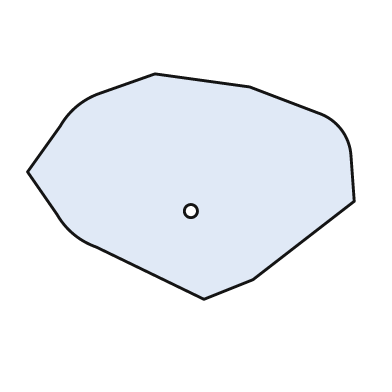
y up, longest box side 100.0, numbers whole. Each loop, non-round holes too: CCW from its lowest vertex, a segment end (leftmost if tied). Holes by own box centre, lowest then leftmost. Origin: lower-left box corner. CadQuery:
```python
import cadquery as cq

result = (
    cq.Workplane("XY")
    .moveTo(54.0, 0.0)
    .lineTo(69.0, 6.0)
    .lineTo(100.0, 30.0)
    .lineTo(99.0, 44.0)
    .threePointArc((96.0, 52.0), (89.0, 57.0))
    .lineTo(68.0, 65.0)
    .lineTo(39.0, 69.0)
    .lineTo(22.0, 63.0)
    .threePointArc((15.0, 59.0), (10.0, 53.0))
    .lineTo(0.0, 39.0)
    .lineTo(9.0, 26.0)
    .threePointArc((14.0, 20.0), (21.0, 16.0))
    .close()
    .moveTo(50.0, 27.0)
    .circle(2.0)
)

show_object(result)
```